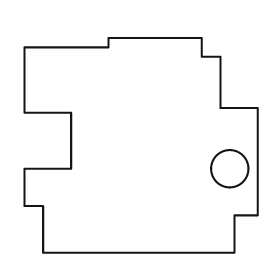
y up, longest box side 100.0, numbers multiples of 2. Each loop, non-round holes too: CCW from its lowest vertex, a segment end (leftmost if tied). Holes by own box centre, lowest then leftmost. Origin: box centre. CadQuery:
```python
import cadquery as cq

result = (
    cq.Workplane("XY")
    .moveTo(-42.0, -46.0)
    .lineTo(40.0, -46.0)
    .lineTo(40.0, -30.0)
    .lineTo(50.0, -30.0)
    .lineTo(50.0, 16.0)
    .lineTo(34.0, 16.0)
    .lineTo(34.0, 38.0)
    .lineTo(26.0, 38.0)
    .lineTo(26.0, 46.0)
    .lineTo(-14.0, 46.0)
    .lineTo(-14.0, 42.0)
    .lineTo(-50.0, 42.0)
    .lineTo(-50.0, 14.0)
    .lineTo(-30.0, 14.0)
    .lineTo(-30.0, -10.0)
    .lineTo(-50.0, -10.0)
    .lineTo(-50.0, -26.0)
    .lineTo(-42.0, -26.0)
    .close()
    .moveTo(38.0, -10.0)
    .circle(8.0)
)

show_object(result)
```